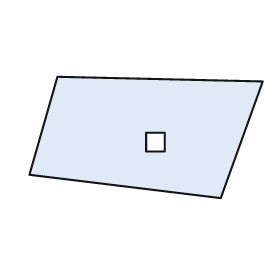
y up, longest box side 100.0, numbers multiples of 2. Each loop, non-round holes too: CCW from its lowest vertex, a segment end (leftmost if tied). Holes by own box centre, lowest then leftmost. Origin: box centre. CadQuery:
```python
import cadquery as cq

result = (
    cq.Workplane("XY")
    .moveTo(32.0, -26.0)
    .lineTo(50.0, 24.0)
    .lineTo(-38.0, 26.0)
    .lineTo(-50.0, -16.0)
    .close()
    .moveTo(0.0, -6.0)
    .lineTo(8.0, -6.0)
    .lineTo(8.0, 2.0)
    .lineTo(0.0, 2.0)
    .close()
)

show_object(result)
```